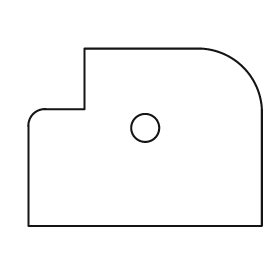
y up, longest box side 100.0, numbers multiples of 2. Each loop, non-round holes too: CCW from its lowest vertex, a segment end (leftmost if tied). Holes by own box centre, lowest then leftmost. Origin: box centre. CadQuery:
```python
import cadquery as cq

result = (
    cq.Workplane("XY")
    .moveTo(-50.0, -38.0)
    .lineTo(50.0, -38.0)
    .lineTo(50.0, 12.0)
    .threePointArc((42.0, 30.0), (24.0, 38.0))
    .lineTo(-26.0, 38.0)
    .lineTo(-26.0, 12.0)
    .lineTo(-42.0, 12.0)
    .threePointArc((-48.0, 10.0), (-50.0, 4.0))
    .close()
    .moveTo(0.0, 4.0)
    .circle(6.0)
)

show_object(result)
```